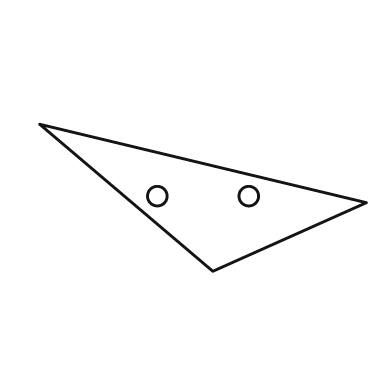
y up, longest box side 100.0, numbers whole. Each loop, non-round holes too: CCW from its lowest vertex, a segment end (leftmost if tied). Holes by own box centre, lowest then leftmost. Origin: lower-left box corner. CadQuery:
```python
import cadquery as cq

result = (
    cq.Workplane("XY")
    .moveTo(53.0, 0.0)
    .lineTo(100.0, 21.0)
    .lineTo(0.0, 45.0)
    .close()
    .moveTo(36.0, 23.0)
    .circle(3.0)
    .moveTo(64.0, 23.0)
    .circle(3.0)
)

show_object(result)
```